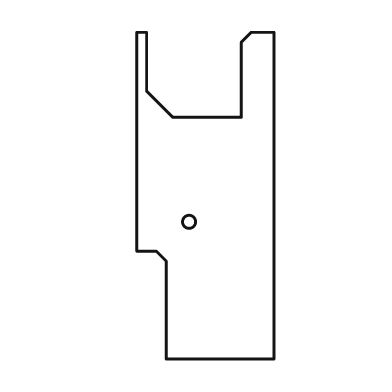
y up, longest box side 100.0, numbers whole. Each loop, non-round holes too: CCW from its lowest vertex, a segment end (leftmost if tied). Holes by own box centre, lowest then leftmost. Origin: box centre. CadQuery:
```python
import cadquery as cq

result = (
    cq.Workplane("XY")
    .moveTo(-12.0, -50.0)
    .lineTo(21.0, -50.0)
    .lineTo(21.0, 50.0)
    .lineTo(14.0, 50.0)
    .lineTo(11.0, 47.0)
    .lineTo(11.0, 24.0)
    .lineTo(-10.0, 24.0)
    .lineTo(-18.0, 32.0)
    .lineTo(-18.0, 50.0)
    .lineTo(-21.0, 50.0)
    .lineTo(-21.0, -17.0)
    .lineTo(-15.0, -17.0)
    .lineTo(-12.0, -20.0)
    .close()
    .moveTo(-5.0, -8.0)
    .circle(2.0)
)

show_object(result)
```